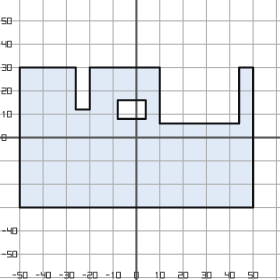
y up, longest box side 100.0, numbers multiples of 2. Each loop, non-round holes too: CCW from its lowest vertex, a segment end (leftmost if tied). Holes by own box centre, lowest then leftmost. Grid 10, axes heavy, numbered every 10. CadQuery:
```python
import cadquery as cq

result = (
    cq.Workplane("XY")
    .moveTo(-50.0, -30.0)
    .lineTo(50.0, -30.0)
    .lineTo(50.0, 30.0)
    .lineTo(44.0, 30.0)
    .lineTo(44.0, 6.0)
    .lineTo(10.0, 6.0)
    .lineTo(10.0, 30.0)
    .lineTo(-20.0, 30.0)
    .lineTo(-20.0, 12.0)
    .lineTo(-26.0, 12.0)
    .lineTo(-26.0, 30.0)
    .lineTo(-50.0, 30.0)
    .close()
    .moveTo(-8.0, 8.0)
    .lineTo(4.0, 8.0)
    .lineTo(4.0, 16.0)
    .lineTo(-8.0, 16.0)
    .close()
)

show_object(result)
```